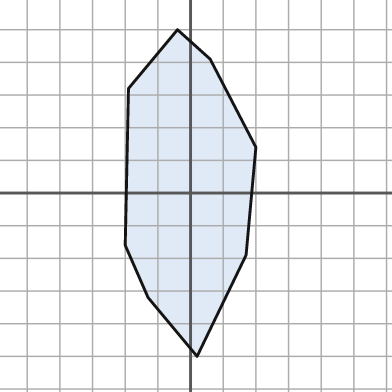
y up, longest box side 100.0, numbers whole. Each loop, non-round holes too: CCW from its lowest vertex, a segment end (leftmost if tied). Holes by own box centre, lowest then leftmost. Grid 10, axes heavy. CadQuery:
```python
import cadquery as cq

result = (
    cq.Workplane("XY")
    .moveTo(2.0, -50.0)
    .lineTo(17.0, -19.0)
    .lineTo(20.0, 14.0)
    .lineTo(6.0, 41.0)
    .lineTo(-4.0, 50.0)
    .lineTo(-19.0, 32.0)
    .lineTo(-20.0, -16.0)
    .lineTo(-13.0, -32.0)
    .close()
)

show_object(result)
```